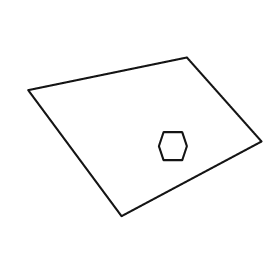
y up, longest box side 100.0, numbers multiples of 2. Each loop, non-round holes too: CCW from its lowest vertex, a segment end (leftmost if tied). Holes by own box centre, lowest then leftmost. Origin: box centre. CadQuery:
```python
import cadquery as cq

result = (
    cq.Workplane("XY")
    .moveTo(-10.0, -34.0)
    .lineTo(50.0, -2.0)
    .lineTo(18.0, 34.0)
    .lineTo(-50.0, 20.0)
    .close()
    .moveTo(8.0, -10.0)
    .lineTo(16.0, -10.0)
    .lineTo(18.0, -4.0)
    .lineTo(16.0, 2.0)
    .lineTo(8.0, 2.0)
    .lineTo(6.0, -4.0)
    .close()
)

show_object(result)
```